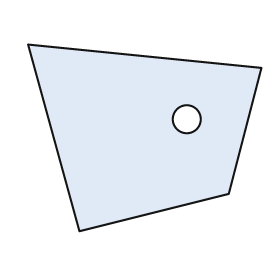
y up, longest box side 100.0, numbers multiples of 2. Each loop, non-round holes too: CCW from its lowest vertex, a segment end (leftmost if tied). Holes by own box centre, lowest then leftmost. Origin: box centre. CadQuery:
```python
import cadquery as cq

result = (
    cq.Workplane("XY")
    .moveTo(-28.0, -40.0)
    .lineTo(36.0, -24.0)
    .lineTo(50.0, 30.0)
    .lineTo(-50.0, 40.0)
    .close()
    .moveTo(18.0, 8.0)
    .circle(6.0)
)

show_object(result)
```